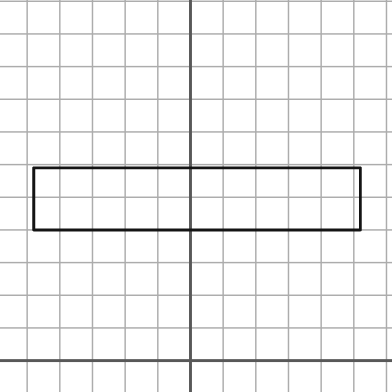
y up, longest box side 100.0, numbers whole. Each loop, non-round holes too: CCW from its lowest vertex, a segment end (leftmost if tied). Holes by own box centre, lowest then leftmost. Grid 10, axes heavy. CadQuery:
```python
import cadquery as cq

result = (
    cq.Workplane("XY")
    .moveTo(-48.0, 40.0)
    .lineTo(52.0, 40.0)
    .lineTo(52.0, 59.0)
    .lineTo(-48.0, 59.0)
    .close()
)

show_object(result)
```